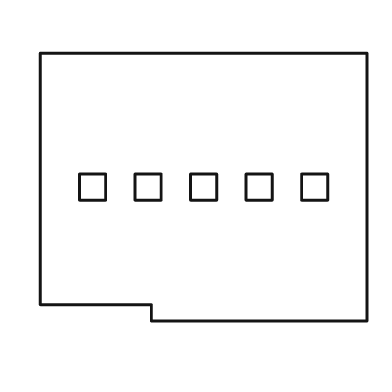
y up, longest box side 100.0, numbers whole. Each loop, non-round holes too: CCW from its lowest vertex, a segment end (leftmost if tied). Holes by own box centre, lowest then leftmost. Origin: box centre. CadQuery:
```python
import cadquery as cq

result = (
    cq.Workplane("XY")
    .moveTo(-16.0, -41.0)
    .lineTo(50.0, -41.0)
    .lineTo(50.0, 41.0)
    .lineTo(-50.0, 41.0)
    .lineTo(-50.0, -36.0)
    .lineTo(-16.0, -36.0)
    .close()
    .moveTo(-38.0, -4.0)
    .lineTo(-30.0, -4.0)
    .lineTo(-30.0, 4.0)
    .lineTo(-38.0, 4.0)
    .close()
    .moveTo(-21.0, -4.0)
    .lineTo(-13.0, -4.0)
    .lineTo(-13.0, 4.0)
    .lineTo(-21.0, 4.0)
    .close()
    .moveTo(-4.0, -4.0)
    .lineTo(4.0, -4.0)
    .lineTo(4.0, 4.0)
    .lineTo(-4.0, 4.0)
    .close()
    .moveTo(13.0, -4.0)
    .lineTo(21.0, -4.0)
    .lineTo(21.0, 4.0)
    .lineTo(13.0, 4.0)
    .close()
    .moveTo(30.0, -4.0)
    .lineTo(38.0, -4.0)
    .lineTo(38.0, 4.0)
    .lineTo(30.0, 4.0)
    .close()
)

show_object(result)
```